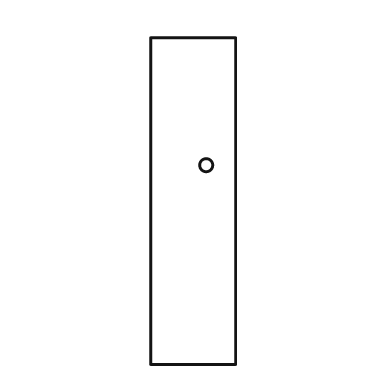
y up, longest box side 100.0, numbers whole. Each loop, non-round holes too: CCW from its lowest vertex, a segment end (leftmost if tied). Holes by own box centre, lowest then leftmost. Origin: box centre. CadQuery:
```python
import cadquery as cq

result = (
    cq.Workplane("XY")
    .moveTo(-13.0, -50.0)
    .lineTo(13.0, -50.0)
    .lineTo(13.0, 50.0)
    .lineTo(-13.0, 50.0)
    .close()
    .moveTo(4.0, 11.0)
    .circle(2.0)
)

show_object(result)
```